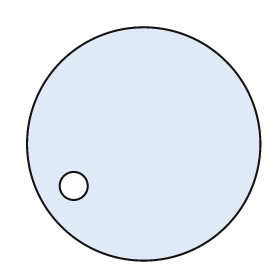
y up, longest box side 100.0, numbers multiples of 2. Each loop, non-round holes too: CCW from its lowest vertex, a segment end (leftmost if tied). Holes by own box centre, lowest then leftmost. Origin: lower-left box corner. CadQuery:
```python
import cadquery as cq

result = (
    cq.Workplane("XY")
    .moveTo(50.0, 50.0)
    .circle(50.0)
    .moveTo(20.0, 32.0)
    .circle(6.0)
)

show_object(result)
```